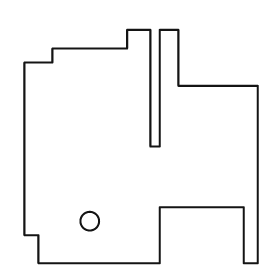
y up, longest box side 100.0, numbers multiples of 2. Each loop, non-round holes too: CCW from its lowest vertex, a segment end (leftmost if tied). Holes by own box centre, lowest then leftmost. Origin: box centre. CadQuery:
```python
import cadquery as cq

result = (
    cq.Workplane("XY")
    .moveTo(-44.0, -50.0)
    .lineTo(8.0, -50.0)
    .lineTo(8.0, -26.0)
    .lineTo(44.0, -26.0)
    .lineTo(44.0, -50.0)
    .lineTo(50.0, -50.0)
    .lineTo(50.0, 26.0)
    .lineTo(16.0, 26.0)
    .lineTo(16.0, 50.0)
    .lineTo(8.0, 50.0)
    .lineTo(8.0, 0.0)
    .lineTo(4.0, 0.0)
    .lineTo(4.0, 50.0)
    .lineTo(-6.0, 50.0)
    .lineTo(-6.0, 42.0)
    .lineTo(-38.0, 42.0)
    .lineTo(-38.0, 36.0)
    .lineTo(-50.0, 36.0)
    .lineTo(-50.0, -38.0)
    .lineTo(-44.0, -38.0)
    .close()
    .moveTo(-22.0, -32.0)
    .circle(4.0)
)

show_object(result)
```